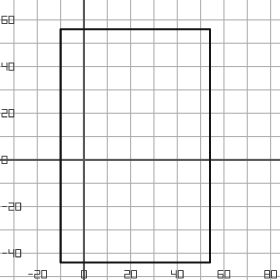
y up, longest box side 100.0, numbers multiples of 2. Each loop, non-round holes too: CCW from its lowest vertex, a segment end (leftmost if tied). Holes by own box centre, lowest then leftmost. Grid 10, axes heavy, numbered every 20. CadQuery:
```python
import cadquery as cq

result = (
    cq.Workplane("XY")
    .moveTo(-10.0, -44.0)
    .lineTo(54.0, -44.0)
    .lineTo(54.0, 56.0)
    .lineTo(-10.0, 56.0)
    .close()
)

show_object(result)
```